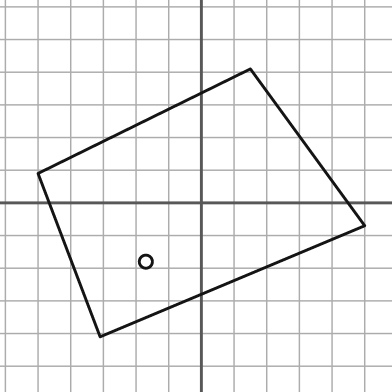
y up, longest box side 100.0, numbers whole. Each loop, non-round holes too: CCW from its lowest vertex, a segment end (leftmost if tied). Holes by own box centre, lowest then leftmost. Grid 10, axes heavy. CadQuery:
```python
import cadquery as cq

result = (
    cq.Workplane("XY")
    .moveTo(-31.0, -41.0)
    .lineTo(50.0, -7.0)
    .lineTo(15.0, 41.0)
    .lineTo(-50.0, 9.0)
    .close()
    .moveTo(-17.0, -18.0)
    .circle(2.0)
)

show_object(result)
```